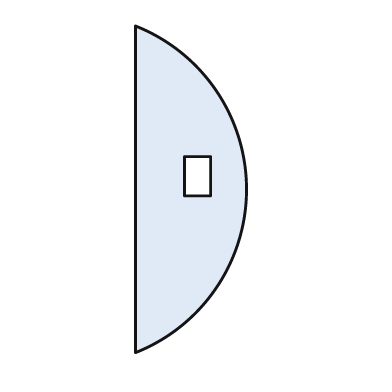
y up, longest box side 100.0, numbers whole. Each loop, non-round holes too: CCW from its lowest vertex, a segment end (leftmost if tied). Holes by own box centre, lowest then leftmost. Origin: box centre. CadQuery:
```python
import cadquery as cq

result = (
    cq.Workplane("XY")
    .moveTo(-17.0, -50.0)
    .threePointArc((17.0, 0.0), (-17.0, 50.0))
    .close()
    .moveTo(-2.0, -2.0)
    .lineTo(6.0, -2.0)
    .lineTo(6.0, 10.0)
    .lineTo(-2.0, 10.0)
    .close()
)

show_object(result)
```